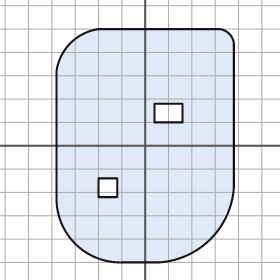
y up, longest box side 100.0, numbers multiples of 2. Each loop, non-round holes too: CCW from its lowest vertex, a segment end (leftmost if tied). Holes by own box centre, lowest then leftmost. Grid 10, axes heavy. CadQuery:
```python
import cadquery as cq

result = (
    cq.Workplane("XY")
    .moveTo(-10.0, -50.0)
    .lineTo(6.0, -50.0)
    .threePointArc((28.0, -40.0), (38.0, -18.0))
    .lineTo(38.0, 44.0)
    .threePointArc((36.0, 48.0), (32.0, 50.0))
    .lineTo(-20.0, 50.0)
    .threePointArc((-32.0, 44.0), (-38.0, 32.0))
    .lineTo(-38.0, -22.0)
    .threePointArc((-30.0, -42.0), (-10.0, -50.0))
    .close()
    .moveTo(-20.0, -22.0)
    .lineTo(-12.0, -22.0)
    .lineTo(-12.0, -14.0)
    .lineTo(-20.0, -14.0)
    .close()
    .moveTo(4.0, 10.0)
    .lineTo(16.0, 10.0)
    .lineTo(16.0, 18.0)
    .lineTo(4.0, 18.0)
    .close()
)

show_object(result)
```